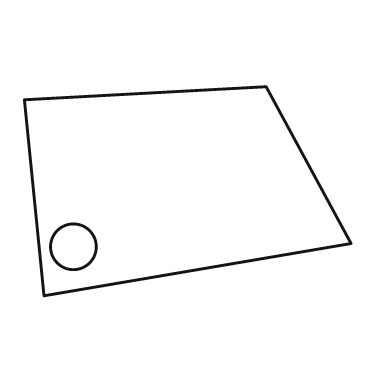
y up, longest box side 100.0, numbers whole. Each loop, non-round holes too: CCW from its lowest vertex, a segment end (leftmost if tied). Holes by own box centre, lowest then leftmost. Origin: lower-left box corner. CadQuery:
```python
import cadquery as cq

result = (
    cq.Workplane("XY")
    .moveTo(6.0, 0.0)
    .lineTo(100.0, 16.0)
    .lineTo(74.0, 64.0)
    .lineTo(0.0, 60.0)
    .close()
    .moveTo(15.0, 15.0)
    .circle(7.0)
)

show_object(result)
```